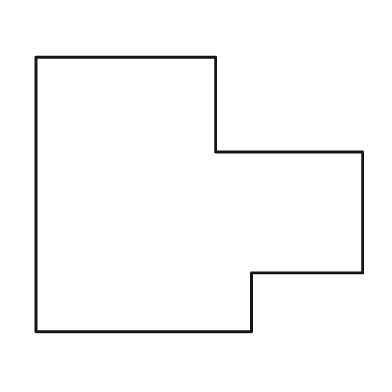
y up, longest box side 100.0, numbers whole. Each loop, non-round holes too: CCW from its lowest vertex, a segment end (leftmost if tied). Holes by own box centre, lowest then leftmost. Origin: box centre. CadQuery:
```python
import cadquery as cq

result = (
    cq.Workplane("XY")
    .moveTo(-50.0, -42.0)
    .lineTo(16.0, -42.0)
    .lineTo(16.0, -24.0)
    .lineTo(50.0, -24.0)
    .lineTo(50.0, 13.0)
    .lineTo(5.0, 13.0)
    .lineTo(5.0, 42.0)
    .lineTo(-50.0, 42.0)
    .close()
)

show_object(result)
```